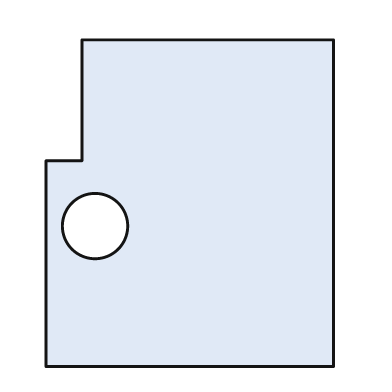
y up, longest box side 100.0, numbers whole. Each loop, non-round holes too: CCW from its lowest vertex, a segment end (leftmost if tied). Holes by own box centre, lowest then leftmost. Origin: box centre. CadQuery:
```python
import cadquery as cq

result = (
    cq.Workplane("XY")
    .moveTo(-44.0, -50.0)
    .lineTo(44.0, -50.0)
    .lineTo(44.0, 50.0)
    .lineTo(-33.0, 50.0)
    .lineTo(-33.0, 13.0)
    .lineTo(-44.0, 13.0)
    .close()
    .moveTo(-29.0, -7.0)
    .circle(10.0)
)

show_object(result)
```